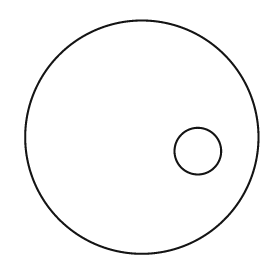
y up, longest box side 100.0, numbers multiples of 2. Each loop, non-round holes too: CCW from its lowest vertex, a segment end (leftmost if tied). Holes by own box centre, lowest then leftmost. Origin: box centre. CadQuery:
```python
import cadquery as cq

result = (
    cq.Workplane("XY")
    .moveTo(0.0, 0.0)
    .circle(50.0)
    .moveTo(24.0, -6.0)
    .circle(10.0)
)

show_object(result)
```